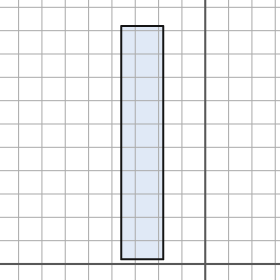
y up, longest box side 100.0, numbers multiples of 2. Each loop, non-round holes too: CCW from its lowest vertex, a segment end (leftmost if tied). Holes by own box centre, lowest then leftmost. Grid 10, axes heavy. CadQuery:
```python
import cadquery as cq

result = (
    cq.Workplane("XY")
    .moveTo(-36.0, 2.0)
    .lineTo(-18.0, 2.0)
    .lineTo(-18.0, 102.0)
    .lineTo(-36.0, 102.0)
    .close()
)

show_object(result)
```